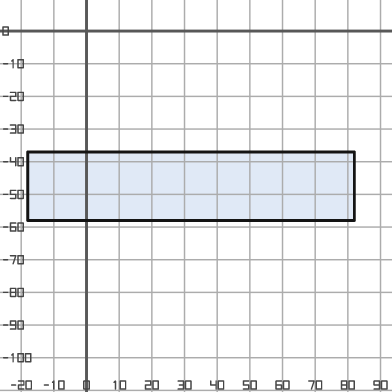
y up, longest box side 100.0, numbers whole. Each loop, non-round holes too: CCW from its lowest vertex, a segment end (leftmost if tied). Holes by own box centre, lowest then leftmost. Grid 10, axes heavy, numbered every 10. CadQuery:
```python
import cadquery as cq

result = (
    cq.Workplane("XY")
    .moveTo(-18.0, -58.0)
    .lineTo(82.0, -58.0)
    .lineTo(82.0, -37.0)
    .lineTo(-18.0, -37.0)
    .close()
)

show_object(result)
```